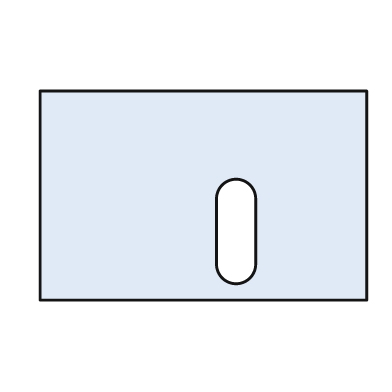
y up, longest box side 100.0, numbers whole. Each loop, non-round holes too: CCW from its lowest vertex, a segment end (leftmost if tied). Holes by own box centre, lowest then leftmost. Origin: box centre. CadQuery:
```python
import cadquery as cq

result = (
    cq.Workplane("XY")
    .moveTo(-50.0, -32.0)
    .lineTo(50.0, -32.0)
    .lineTo(50.0, 32.0)
    .lineTo(-50.0, 32.0)
    .close()
    .moveTo(4.0, -21.0)
    .threePointArc((10.0, -27.0), (16.0, -21.0))
    .lineTo(16.0, -1.0)
    .threePointArc((10.0, 5.0), (4.0, -1.0))
    .close()
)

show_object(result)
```